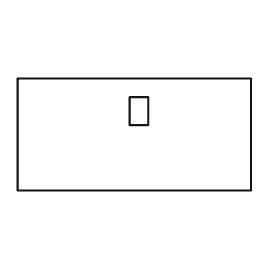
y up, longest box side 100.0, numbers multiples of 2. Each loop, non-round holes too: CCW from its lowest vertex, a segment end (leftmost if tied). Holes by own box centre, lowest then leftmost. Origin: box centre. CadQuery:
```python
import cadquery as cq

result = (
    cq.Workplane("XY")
    .moveTo(-50.0, -24.0)
    .lineTo(50.0, -24.0)
    .lineTo(50.0, 24.0)
    .lineTo(-50.0, 24.0)
    .close()
    .moveTo(-2.0, 4.0)
    .lineTo(6.0, 4.0)
    .lineTo(6.0, 16.0)
    .lineTo(-2.0, 16.0)
    .close()
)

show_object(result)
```